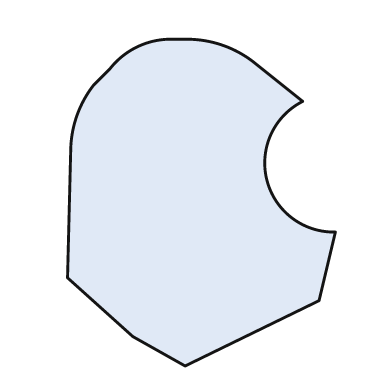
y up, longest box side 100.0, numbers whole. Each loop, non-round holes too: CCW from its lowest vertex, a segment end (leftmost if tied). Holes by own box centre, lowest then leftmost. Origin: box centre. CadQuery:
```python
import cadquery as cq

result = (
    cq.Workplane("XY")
    .moveTo(-5.0, -50.0)
    .lineTo(36.0, -30.0)
    .lineTo(41.0, -9.0)
    .threePointArc((20.0, 7.0), (31.0, 31.0))
    .lineTo(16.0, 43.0)
    .threePointArc((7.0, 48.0), (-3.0, 50.0))
    .lineTo(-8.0, 50.0)
    .threePointArc((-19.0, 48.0), (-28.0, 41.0))
    .lineTo(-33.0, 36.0)
    .threePointArc((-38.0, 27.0), (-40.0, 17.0))
    .lineTo(-41.0, -23.0)
    .lineTo(-21.0, -41.0)
    .close()
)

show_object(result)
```